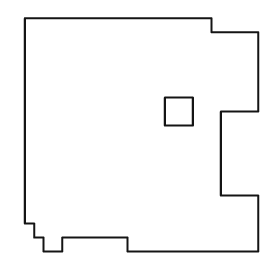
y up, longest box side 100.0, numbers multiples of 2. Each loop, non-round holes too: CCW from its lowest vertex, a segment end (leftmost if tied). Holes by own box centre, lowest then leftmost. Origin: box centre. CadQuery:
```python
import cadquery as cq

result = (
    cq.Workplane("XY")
    .moveTo(-42.0, -50.0)
    .lineTo(-34.0, -50.0)
    .lineTo(-34.0, -44.0)
    .lineTo(-6.0, -44.0)
    .lineTo(-6.0, -50.0)
    .lineTo(50.0, -50.0)
    .lineTo(50.0, -26.0)
    .lineTo(34.0, -26.0)
    .lineTo(34.0, 10.0)
    .lineTo(50.0, 10.0)
    .lineTo(50.0, 44.0)
    .lineTo(30.0, 44.0)
    .lineTo(30.0, 50.0)
    .lineTo(-50.0, 50.0)
    .lineTo(-50.0, -38.0)
    .lineTo(-46.0, -38.0)
    .lineTo(-46.0, -44.0)
    .lineTo(-42.0, -44.0)
    .close()
    .moveTo(10.0, 4.0)
    .lineTo(22.0, 4.0)
    .lineTo(22.0, 16.0)
    .lineTo(10.0, 16.0)
    .close()
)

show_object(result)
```